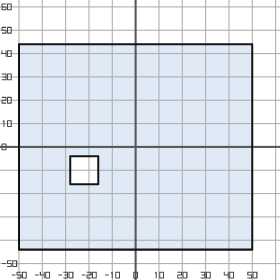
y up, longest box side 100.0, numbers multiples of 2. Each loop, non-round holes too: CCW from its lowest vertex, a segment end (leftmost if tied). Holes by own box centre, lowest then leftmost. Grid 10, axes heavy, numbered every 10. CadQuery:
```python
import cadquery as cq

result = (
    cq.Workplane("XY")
    .moveTo(-50.0, -44.0)
    .lineTo(50.0, -44.0)
    .lineTo(50.0, 44.0)
    .lineTo(-50.0, 44.0)
    .close()
    .moveTo(-28.0, -16.0)
    .lineTo(-16.0, -16.0)
    .lineTo(-16.0, -4.0)
    .lineTo(-28.0, -4.0)
    .close()
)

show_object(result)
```